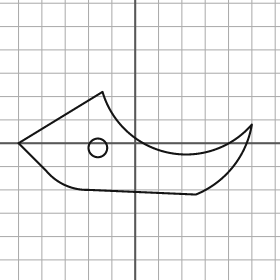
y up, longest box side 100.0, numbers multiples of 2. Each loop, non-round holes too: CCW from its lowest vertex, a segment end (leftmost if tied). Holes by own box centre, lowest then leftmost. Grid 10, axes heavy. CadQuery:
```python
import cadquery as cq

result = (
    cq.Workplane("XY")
    .moveTo(26.0, -22.0)
    .threePointArc((42.0, -10.0), (50.0, 8.0))
    .threePointArc((14.0, -4.0), (-14.0, 22.0))
    .lineTo(-50.0, 0.0)
    .lineTo(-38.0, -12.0)
    .threePointArc((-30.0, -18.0), (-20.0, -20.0))
    .close()
    .moveTo(-16.0, -2.0)
    .circle(4.0)
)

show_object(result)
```